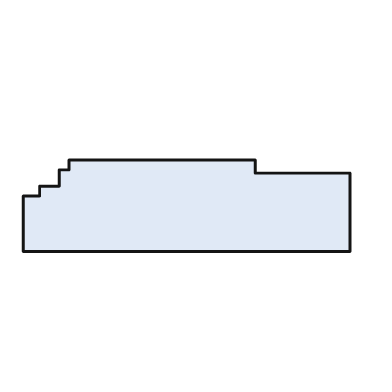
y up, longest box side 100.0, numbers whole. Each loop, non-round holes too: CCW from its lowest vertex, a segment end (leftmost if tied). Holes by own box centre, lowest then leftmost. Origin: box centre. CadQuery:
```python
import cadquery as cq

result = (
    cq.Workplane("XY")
    .moveTo(-50.0, -14.0)
    .lineTo(50.0, -14.0)
    .lineTo(50.0, 10.0)
    .lineTo(21.0, 10.0)
    .lineTo(21.0, 14.0)
    .lineTo(-36.0, 14.0)
    .lineTo(-36.0, 11.0)
    .lineTo(-39.0, 11.0)
    .lineTo(-39.0, 6.0)
    .lineTo(-45.0, 6.0)
    .lineTo(-45.0, 3.0)
    .lineTo(-50.0, 3.0)
    .close()
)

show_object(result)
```